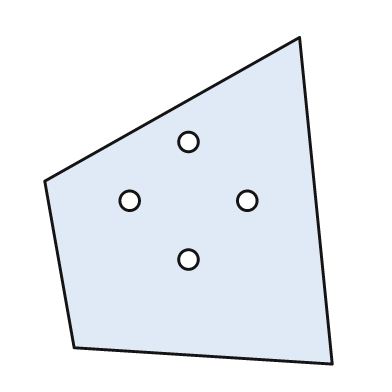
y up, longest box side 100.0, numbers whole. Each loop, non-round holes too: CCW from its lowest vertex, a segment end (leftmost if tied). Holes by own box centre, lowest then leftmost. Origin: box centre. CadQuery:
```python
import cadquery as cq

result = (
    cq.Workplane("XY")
    .moveTo(44.0, -50.0)
    .lineTo(34.0, 50.0)
    .lineTo(-44.0, 6.0)
    .lineTo(-35.0, -45.0)
    .close()
    .moveTo(0.0, -18.0)
    .circle(3.0)
    .moveTo(-18.0, 0.0)
    .circle(3.0)
    .moveTo(18.0, 0.0)
    .circle(3.0)
    .moveTo(0.0, 18.0)
    .circle(3.0)
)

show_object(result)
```